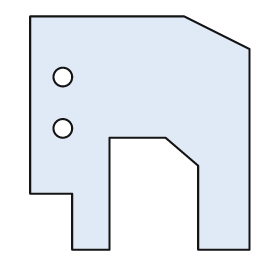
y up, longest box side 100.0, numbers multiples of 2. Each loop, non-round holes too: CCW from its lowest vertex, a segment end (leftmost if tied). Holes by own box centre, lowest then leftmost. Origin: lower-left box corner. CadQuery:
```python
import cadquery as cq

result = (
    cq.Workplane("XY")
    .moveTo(18.0, 0.0)
    .lineTo(34.0, 0.0)
    .lineTo(34.0, 48.0)
    .lineTo(58.0, 48.0)
    .lineTo(72.0, 36.0)
    .lineTo(72.0, 0.0)
    .lineTo(94.0, 0.0)
    .lineTo(94.0, 86.0)
    .lineTo(66.0, 100.0)
    .lineTo(0.0, 100.0)
    .lineTo(0.0, 24.0)
    .lineTo(18.0, 24.0)
    .close()
    .moveTo(14.0, 52.0)
    .circle(4.0)
    .moveTo(14.0, 74.0)
    .circle(4.0)
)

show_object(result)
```